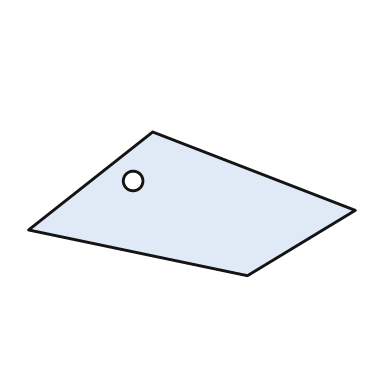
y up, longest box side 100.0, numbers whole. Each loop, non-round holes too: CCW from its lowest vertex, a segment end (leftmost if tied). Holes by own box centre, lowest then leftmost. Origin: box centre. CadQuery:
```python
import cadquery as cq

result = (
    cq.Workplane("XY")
    .moveTo(17.0, -22.0)
    .lineTo(50.0, -2.0)
    .lineTo(-12.0, 22.0)
    .lineTo(-50.0, -8.0)
    .close()
    .moveTo(-18.0, 7.0)
    .circle(3.0)
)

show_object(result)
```